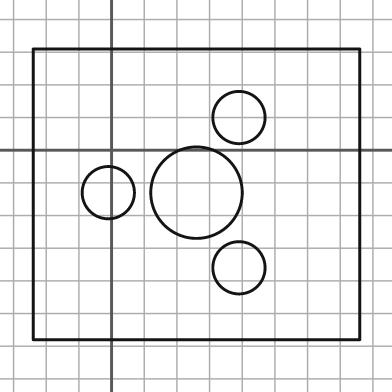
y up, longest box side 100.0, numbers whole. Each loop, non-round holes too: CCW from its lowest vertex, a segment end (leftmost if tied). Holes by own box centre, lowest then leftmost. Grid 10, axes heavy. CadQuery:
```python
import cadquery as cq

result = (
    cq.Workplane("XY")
    .moveTo(-24.0, -58.0)
    .lineTo(76.0, -58.0)
    .lineTo(76.0, 31.0)
    .lineTo(-24.0, 31.0)
    .close()
    .moveTo(39.0, -36.0)
    .circle(8.0)
    .moveTo(-1.0, -13.0)
    .circle(8.0)
    .moveTo(26.0, -13.0)
    .circle(14.0)
    .moveTo(39.0, 10.0)
    .circle(8.0)
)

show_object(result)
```